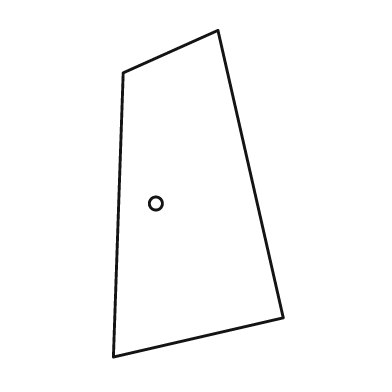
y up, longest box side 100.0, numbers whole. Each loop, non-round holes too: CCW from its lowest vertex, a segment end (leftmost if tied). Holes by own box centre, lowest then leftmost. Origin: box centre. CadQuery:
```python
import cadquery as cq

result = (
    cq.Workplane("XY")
    .moveTo(-26.0, -50.0)
    .lineTo(26.0, -38.0)
    .lineTo(6.0, 50.0)
    .lineTo(-23.0, 37.0)
    .close()
    .moveTo(-13.0, -3.0)
    .circle(2.0)
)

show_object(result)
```